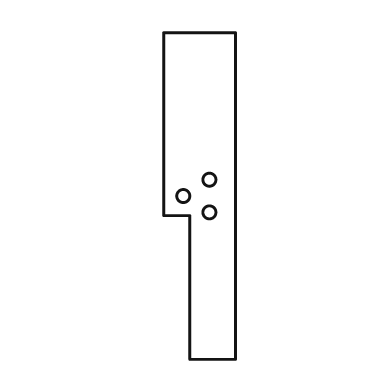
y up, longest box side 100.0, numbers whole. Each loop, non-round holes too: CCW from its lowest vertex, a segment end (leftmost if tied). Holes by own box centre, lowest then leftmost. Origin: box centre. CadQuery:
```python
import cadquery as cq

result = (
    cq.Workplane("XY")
    .moveTo(-3.0, -50.0)
    .lineTo(11.0, -50.0)
    .lineTo(11.0, 50.0)
    .lineTo(-11.0, 50.0)
    .lineTo(-11.0, -6.0)
    .lineTo(-3.0, -6.0)
    .close()
    .moveTo(3.0, -5.0)
    .circle(2.0)
    .moveTo(-5.0, 0.0)
    .circle(2.0)
    .moveTo(3.0, 5.0)
    .circle(2.0)
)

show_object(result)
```